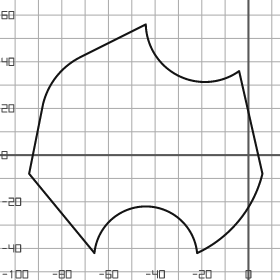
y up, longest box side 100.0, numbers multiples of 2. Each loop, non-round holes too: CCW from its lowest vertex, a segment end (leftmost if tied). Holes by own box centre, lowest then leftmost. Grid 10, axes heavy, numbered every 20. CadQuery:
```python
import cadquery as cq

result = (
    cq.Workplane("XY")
    .moveTo(-66.0, -42.0)
    .threePointArc((-44.0, -22.0), (-22.0, -42.0))
    .threePointArc((-4.0, -28.0), (6.0, -8.0))
    .lineTo(-4.0, 36.0)
    .threePointArc((-30.0, 34.0), (-44.0, 56.0))
    .lineTo(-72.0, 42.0)
    .threePointArc((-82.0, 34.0), (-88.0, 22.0))
    .lineTo(-94.0, -8.0)
    .close()
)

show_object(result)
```